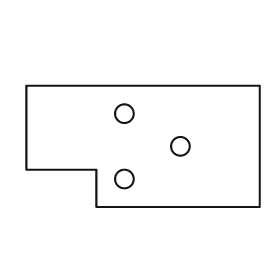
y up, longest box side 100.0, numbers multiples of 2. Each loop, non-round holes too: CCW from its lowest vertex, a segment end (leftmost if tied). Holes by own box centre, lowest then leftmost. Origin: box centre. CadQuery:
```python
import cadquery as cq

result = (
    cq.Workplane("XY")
    .moveTo(-20.0, -26.0)
    .lineTo(50.0, -26.0)
    .lineTo(50.0, 26.0)
    .lineTo(-50.0, 26.0)
    .lineTo(-50.0, -10.0)
    .lineTo(-20.0, -10.0)
    .close()
    .moveTo(-8.0, -14.0)
    .circle(4.0)
    .moveTo(16.0, 0.0)
    .circle(4.0)
    .moveTo(-8.0, 14.0)
    .circle(4.0)
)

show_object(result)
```